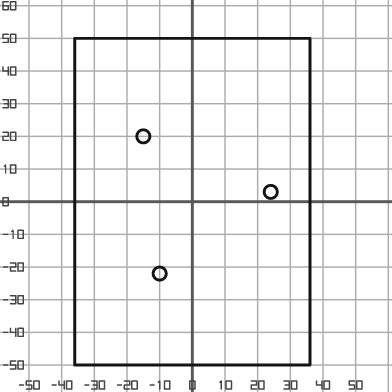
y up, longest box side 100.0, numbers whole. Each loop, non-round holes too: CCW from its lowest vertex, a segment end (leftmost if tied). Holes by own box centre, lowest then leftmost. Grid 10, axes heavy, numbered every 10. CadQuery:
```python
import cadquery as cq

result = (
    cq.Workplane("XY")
    .moveTo(-36.0, -50.0)
    .lineTo(36.0, -50.0)
    .lineTo(36.0, 50.0)
    .lineTo(-36.0, 50.0)
    .close()
    .moveTo(-10.0, -22.0)
    .circle(2.0)
    .moveTo(24.0, 3.0)
    .circle(2.0)
    .moveTo(-15.0, 20.0)
    .circle(2.0)
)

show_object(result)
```